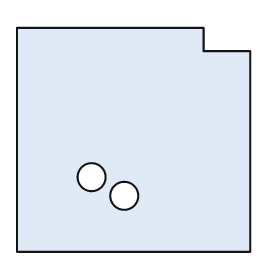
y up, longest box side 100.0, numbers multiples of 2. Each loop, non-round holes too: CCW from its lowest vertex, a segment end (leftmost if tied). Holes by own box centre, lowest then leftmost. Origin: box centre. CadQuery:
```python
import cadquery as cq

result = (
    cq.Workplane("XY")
    .moveTo(-50.0, -48.0)
    .lineTo(50.0, -48.0)
    .lineTo(50.0, 38.0)
    .lineTo(30.0, 38.0)
    .lineTo(30.0, 48.0)
    .lineTo(-50.0, 48.0)
    .close()
    .moveTo(-4.0, -24.0)
    .circle(6.0)
    .moveTo(-18.0, -16.0)
    .circle(6.0)
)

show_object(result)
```